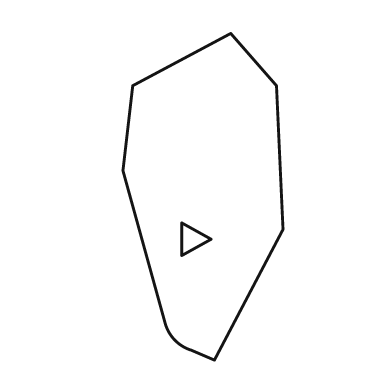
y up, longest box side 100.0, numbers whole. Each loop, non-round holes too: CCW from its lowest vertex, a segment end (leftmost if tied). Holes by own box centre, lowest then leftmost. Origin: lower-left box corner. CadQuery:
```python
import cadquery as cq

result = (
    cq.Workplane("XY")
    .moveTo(28.0, 0.0)
    .lineTo(49.0, 40.0)
    .lineTo(47.0, 84.0)
    .lineTo(33.0, 100.0)
    .lineTo(3.0, 84.0)
    .lineTo(0.0, 58.0)
    .lineTo(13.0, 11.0)
    .threePointArc((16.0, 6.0), (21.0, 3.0))
    .close()
    .moveTo(18.0, 32.0)
    .lineTo(27.0, 37.0)
    .lineTo(18.0, 42.0)
    .close()
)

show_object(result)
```